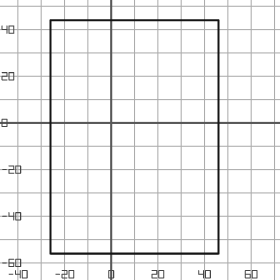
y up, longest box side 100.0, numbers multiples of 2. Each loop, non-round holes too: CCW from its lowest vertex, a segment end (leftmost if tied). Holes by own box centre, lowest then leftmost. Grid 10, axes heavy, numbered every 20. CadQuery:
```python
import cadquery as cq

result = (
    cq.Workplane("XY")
    .moveTo(-26.0, -56.0)
    .lineTo(46.0, -56.0)
    .lineTo(46.0, 44.0)
    .lineTo(-26.0, 44.0)
    .close()
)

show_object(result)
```